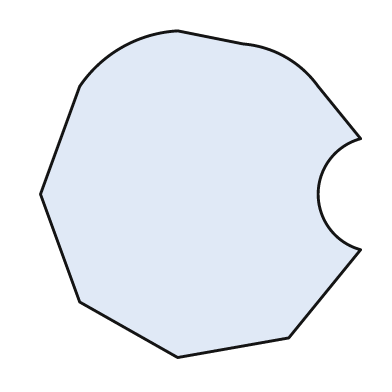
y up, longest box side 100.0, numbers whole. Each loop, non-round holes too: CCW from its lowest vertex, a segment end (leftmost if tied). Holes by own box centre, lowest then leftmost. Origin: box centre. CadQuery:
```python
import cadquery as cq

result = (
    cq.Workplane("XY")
    .moveTo(-7.0, -50.0)
    .lineTo(27.0, -44.0)
    .lineTo(49.0, -17.0)
    .threePointArc((36.0, 0.0), (49.0, 17.0))
    .lineTo(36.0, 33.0)
    .threePointArc((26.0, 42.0), (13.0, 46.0))
    .lineTo(-7.0, 50.0)
    .threePointArc((-24.0, 45.0), (-37.0, 33.0))
    .lineTo(-49.0, 0.0)
    .lineTo(-37.0, -33.0)
    .close()
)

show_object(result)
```